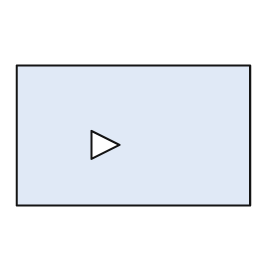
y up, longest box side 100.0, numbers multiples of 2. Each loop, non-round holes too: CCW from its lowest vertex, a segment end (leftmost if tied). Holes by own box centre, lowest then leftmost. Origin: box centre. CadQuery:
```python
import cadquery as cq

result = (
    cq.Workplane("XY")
    .moveTo(-50.0, -30.0)
    .lineTo(50.0, -30.0)
    .lineTo(50.0, 30.0)
    .lineTo(-50.0, 30.0)
    .close()
    .moveTo(-18.0, -10.0)
    .lineTo(-6.0, -4.0)
    .lineTo(-18.0, 2.0)
    .close()
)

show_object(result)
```